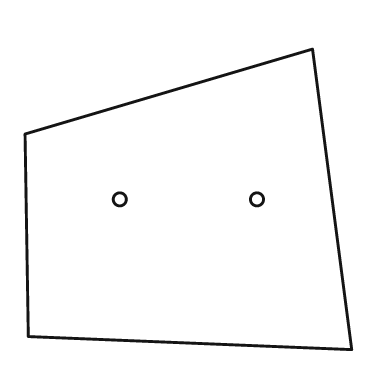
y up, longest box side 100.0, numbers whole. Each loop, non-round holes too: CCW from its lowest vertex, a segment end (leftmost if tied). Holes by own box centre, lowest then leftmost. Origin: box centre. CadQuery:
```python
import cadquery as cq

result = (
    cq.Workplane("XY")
    .moveTo(50.0, -46.0)
    .lineTo(38.0, 46.0)
    .lineTo(-50.0, 20.0)
    .lineTo(-49.0, -42.0)
    .close()
    .moveTo(-21.0, 0.0)
    .circle(2.0)
    .moveTo(21.0, 0.0)
    .circle(2.0)
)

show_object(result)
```